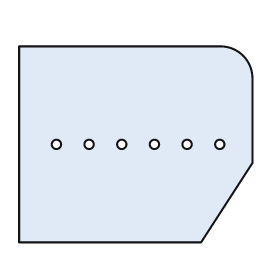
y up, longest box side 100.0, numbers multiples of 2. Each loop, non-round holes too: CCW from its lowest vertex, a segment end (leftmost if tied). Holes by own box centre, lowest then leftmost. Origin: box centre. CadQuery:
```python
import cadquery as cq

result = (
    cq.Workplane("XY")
    .moveTo(-50.0, -42.0)
    .lineTo(28.0, -42.0)
    .lineTo(50.0, -8.0)
    .lineTo(50.0, 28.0)
    .threePointArc((46.0, 38.0), (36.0, 42.0))
    .lineTo(-50.0, 42.0)
    .close()
    .moveTo(-34.0, 0.0)
    .circle(2.0)
    .moveTo(-20.0, 0.0)
    .circle(2.0)
    .moveTo(-6.0, 0.0)
    .circle(2.0)
    .moveTo(8.0, 0.0)
    .circle(2.0)
    .moveTo(22.0, 0.0)
    .circle(2.0)
    .moveTo(36.0, 0.0)
    .circle(2.0)
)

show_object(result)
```